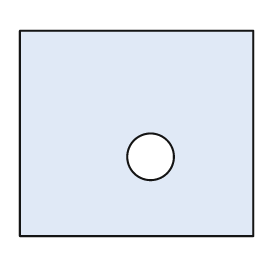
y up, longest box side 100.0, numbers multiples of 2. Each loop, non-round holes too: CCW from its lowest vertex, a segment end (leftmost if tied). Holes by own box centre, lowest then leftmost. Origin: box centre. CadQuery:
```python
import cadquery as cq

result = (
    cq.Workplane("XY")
    .moveTo(-50.0, -44.0)
    .lineTo(50.0, -44.0)
    .lineTo(50.0, 44.0)
    .lineTo(-50.0, 44.0)
    .close()
    .moveTo(6.0, -10.0)
    .circle(10.0)
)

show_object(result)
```